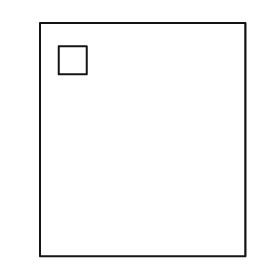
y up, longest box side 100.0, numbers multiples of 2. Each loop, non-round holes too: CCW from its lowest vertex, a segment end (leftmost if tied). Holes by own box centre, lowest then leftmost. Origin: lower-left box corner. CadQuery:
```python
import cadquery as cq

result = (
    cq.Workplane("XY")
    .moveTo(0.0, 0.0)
    .lineTo(88.0, 0.0)
    .lineTo(88.0, 100.0)
    .lineTo(0.0, 100.0)
    .close()
    .moveTo(8.0, 78.0)
    .lineTo(20.0, 78.0)
    .lineTo(20.0, 90.0)
    .lineTo(8.0, 90.0)
    .close()
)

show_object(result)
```